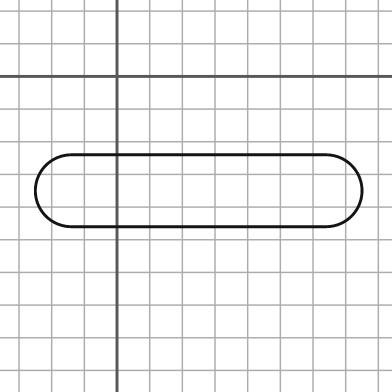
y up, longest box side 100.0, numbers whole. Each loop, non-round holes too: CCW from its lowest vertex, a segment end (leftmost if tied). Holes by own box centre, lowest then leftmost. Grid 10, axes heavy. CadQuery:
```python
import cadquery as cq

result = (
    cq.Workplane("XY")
    .moveTo(-14.0, -46.0)
    .lineTo(64.0, -46.0)
    .threePointArc((75.0, -35.0), (64.0, -24.0))
    .lineTo(-14.0, -24.0)
    .threePointArc((-25.0, -35.0), (-14.0, -46.0))
    .close()
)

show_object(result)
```